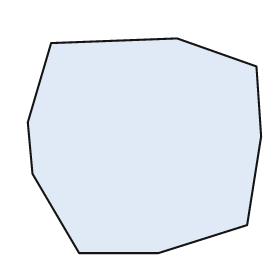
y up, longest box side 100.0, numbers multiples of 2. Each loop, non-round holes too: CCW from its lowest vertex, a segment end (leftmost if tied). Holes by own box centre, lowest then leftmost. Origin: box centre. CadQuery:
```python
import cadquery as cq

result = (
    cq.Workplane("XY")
    .moveTo(-28.0, -46.0)
    .lineTo(6.0, -46.0)
    .lineTo(44.0, -34.0)
    .lineTo(50.0, 4.0)
    .lineTo(48.0, 34.0)
    .lineTo(14.0, 46.0)
    .lineTo(-40.0, 44.0)
    .lineTo(-50.0, 10.0)
    .lineTo(-48.0, -12.0)
    .close()
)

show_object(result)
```